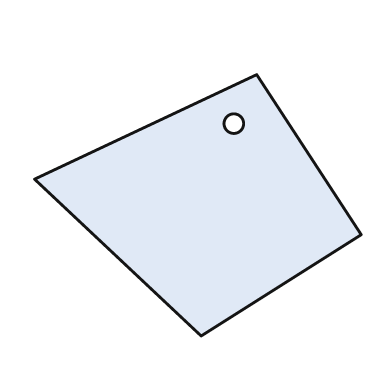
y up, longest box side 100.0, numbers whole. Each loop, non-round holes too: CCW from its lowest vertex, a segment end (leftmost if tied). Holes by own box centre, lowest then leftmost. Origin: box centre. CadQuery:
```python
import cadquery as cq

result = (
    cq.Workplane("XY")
    .moveTo(1.0, -40.0)
    .lineTo(50.0, -9.0)
    .lineTo(18.0, 40.0)
    .lineTo(-50.0, 8.0)
    .close()
    .moveTo(11.0, 25.0)
    .circle(3.0)
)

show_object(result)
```